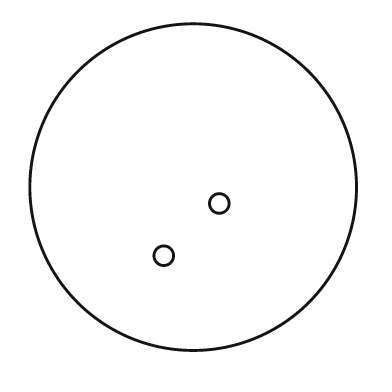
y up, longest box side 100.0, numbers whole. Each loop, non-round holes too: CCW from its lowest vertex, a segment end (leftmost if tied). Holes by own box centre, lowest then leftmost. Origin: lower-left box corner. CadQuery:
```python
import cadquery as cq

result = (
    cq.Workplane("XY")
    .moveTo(50.0, 50.0)
    .circle(50.0)
    .moveTo(41.0, 29.0)
    .circle(3.0)
    .moveTo(58.0, 45.0)
    .circle(3.0)
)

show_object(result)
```